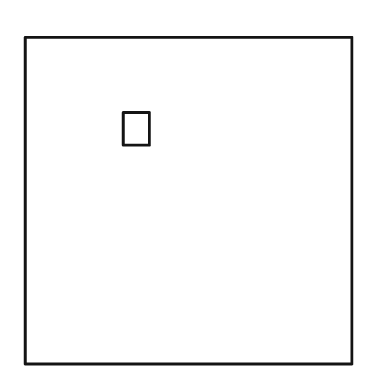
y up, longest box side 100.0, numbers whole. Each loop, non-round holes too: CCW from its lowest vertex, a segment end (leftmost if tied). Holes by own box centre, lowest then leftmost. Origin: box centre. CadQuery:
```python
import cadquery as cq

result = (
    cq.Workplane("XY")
    .moveTo(-50.0, -50.0)
    .lineTo(50.0, -50.0)
    .lineTo(50.0, 50.0)
    .lineTo(-50.0, 50.0)
    .close()
    .moveTo(-20.0, 17.0)
    .lineTo(-12.0, 17.0)
    .lineTo(-12.0, 27.0)
    .lineTo(-20.0, 27.0)
    .close()
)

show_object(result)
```